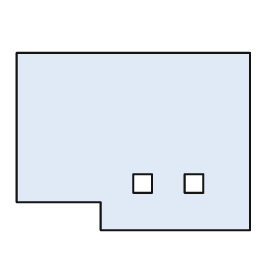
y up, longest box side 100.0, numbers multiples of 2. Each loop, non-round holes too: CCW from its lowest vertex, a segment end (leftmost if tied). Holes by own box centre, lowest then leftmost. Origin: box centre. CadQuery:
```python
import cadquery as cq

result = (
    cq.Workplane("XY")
    .moveTo(-14.0, -38.0)
    .lineTo(50.0, -38.0)
    .lineTo(50.0, 38.0)
    .lineTo(-50.0, 38.0)
    .lineTo(-50.0, -26.0)
    .lineTo(-14.0, -26.0)
    .close()
    .moveTo(0.0, -22.0)
    .lineTo(8.0, -22.0)
    .lineTo(8.0, -14.0)
    .lineTo(0.0, -14.0)
    .close()
    .moveTo(22.0, -22.0)
    .lineTo(30.0, -22.0)
    .lineTo(30.0, -14.0)
    .lineTo(22.0, -14.0)
    .close()
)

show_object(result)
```